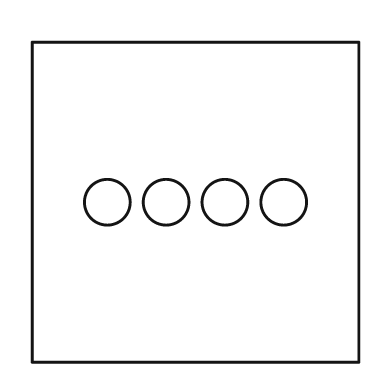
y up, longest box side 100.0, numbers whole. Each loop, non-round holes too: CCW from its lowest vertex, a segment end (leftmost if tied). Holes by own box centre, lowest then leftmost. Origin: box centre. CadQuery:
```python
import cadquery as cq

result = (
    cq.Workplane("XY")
    .moveTo(-50.0, -49.0)
    .lineTo(50.0, -49.0)
    .lineTo(50.0, 49.0)
    .lineTo(-50.0, 49.0)
    .close()
    .moveTo(-27.0, 0.0)
    .circle(7.0)
    .moveTo(-9.0, 0.0)
    .circle(7.0)
    .moveTo(9.0, 0.0)
    .circle(7.0)
    .moveTo(27.0, 0.0)
    .circle(7.0)
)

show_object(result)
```